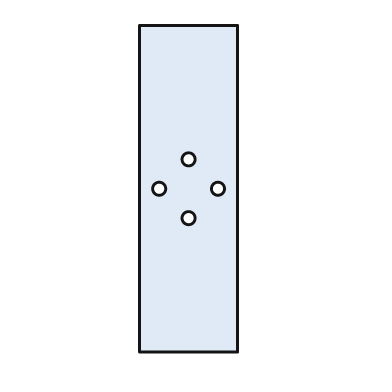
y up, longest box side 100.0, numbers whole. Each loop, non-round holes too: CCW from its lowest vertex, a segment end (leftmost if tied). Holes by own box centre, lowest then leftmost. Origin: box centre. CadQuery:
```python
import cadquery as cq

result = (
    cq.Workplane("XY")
    .moveTo(-15.0, -50.0)
    .lineTo(15.0, -50.0)
    .lineTo(15.0, 50.0)
    .lineTo(-15.0, 50.0)
    .close()
    .moveTo(0.0, -9.0)
    .circle(2.0)
    .moveTo(-9.0, 0.0)
    .circle(2.0)
    .moveTo(9.0, 0.0)
    .circle(2.0)
    .moveTo(0.0, 9.0)
    .circle(2.0)
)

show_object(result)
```